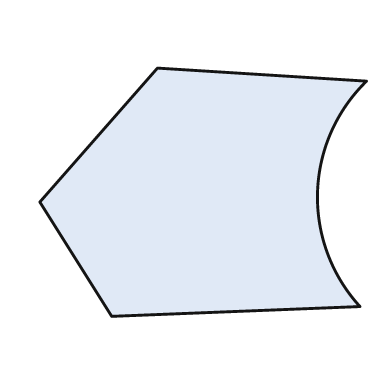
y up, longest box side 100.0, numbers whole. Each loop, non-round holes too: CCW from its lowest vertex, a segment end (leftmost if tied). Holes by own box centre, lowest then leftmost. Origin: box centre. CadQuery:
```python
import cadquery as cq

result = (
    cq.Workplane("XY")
    .moveTo(-28.0, -38.0)
    .lineTo(48.0, -35.0)
    .threePointArc((35.0, 0.0), (50.0, 34.0))
    .lineTo(-14.0, 38.0)
    .lineTo(-50.0, -3.0)
    .close()
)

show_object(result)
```